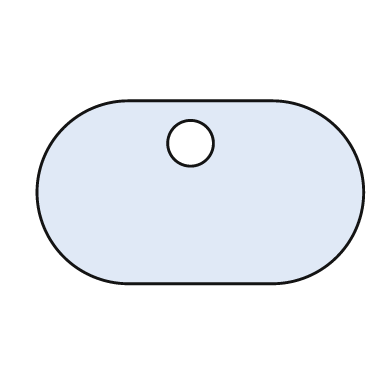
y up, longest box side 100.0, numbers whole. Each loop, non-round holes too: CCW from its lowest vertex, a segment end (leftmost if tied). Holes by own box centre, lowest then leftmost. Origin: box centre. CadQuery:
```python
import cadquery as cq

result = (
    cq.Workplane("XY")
    .moveTo(-22.0, -28.0)
    .lineTo(22.0, -28.0)
    .threePointArc((50.0, 0.0), (22.0, 28.0))
    .lineTo(-22.0, 28.0)
    .threePointArc((-50.0, 0.0), (-22.0, -28.0))
    .close()
    .moveTo(-3.0, 15.0)
    .circle(7.0)
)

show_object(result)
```